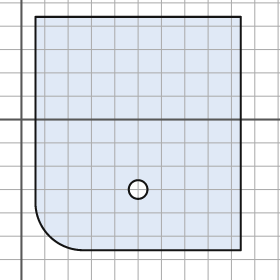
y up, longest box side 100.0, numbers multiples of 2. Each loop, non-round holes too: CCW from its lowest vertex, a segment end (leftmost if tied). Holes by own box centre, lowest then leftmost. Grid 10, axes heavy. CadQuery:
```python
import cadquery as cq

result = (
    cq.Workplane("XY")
    .moveTo(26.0, -56.0)
    .lineTo(94.0, -56.0)
    .lineTo(94.0, 44.0)
    .lineTo(6.0, 44.0)
    .lineTo(6.0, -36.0)
    .threePointArc((12.0, -50.0), (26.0, -56.0))
    .close()
    .moveTo(50.0, -30.0)
    .circle(4.0)
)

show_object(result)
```